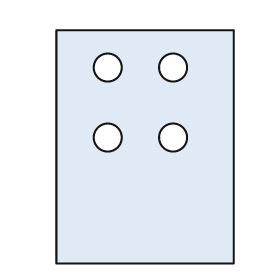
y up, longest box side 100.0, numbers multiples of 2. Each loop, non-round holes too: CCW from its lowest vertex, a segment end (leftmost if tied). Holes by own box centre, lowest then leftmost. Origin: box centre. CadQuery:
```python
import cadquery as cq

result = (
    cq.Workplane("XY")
    .moveTo(-38.0, -50.0)
    .lineTo(38.0, -50.0)
    .lineTo(38.0, 50.0)
    .lineTo(-38.0, 50.0)
    .close()
    .moveTo(-16.0, 4.0)
    .circle(6.0)
    .moveTo(12.0, 4.0)
    .circle(6.0)
    .moveTo(-16.0, 34.0)
    .circle(6.0)
    .moveTo(12.0, 34.0)
    .circle(6.0)
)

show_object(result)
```